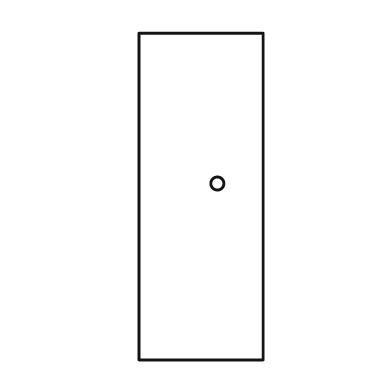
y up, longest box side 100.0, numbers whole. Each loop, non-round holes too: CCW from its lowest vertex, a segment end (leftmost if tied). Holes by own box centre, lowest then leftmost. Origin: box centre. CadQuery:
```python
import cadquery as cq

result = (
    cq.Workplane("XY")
    .moveTo(-19.0, -50.0)
    .lineTo(19.0, -50.0)
    .lineTo(19.0, 50.0)
    .lineTo(-19.0, 50.0)
    .close()
    .moveTo(5.0, 4.0)
    .circle(2.0)
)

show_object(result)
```